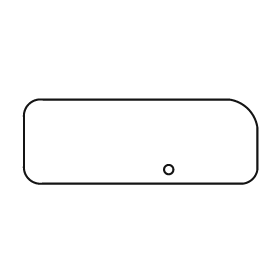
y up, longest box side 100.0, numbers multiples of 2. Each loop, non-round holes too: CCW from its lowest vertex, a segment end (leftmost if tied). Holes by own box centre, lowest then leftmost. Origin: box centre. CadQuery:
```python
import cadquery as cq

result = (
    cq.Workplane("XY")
    .moveTo(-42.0, -18.0)
    .lineTo(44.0, -18.0)
    .threePointArc((48.0, -16.0), (50.0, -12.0))
    .lineTo(50.0, 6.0)
    .threePointArc((46.0, 14.0), (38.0, 18.0))
    .lineTo(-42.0, 18.0)
    .threePointArc((-48.0, 16.0), (-50.0, 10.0))
    .lineTo(-50.0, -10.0)
    .threePointArc((-48.0, -16.0), (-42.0, -18.0))
    .close()
    .moveTo(12.0, -12.0)
    .circle(2.0)
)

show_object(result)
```